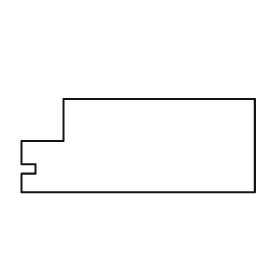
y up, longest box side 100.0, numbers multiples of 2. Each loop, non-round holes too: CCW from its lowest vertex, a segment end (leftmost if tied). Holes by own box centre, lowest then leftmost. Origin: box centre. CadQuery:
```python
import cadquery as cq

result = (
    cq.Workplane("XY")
    .moveTo(-50.0, -20.0)
    .lineTo(50.0, -20.0)
    .lineTo(50.0, 20.0)
    .lineTo(-32.0, 20.0)
    .lineTo(-32.0, 2.0)
    .lineTo(-50.0, 2.0)
    .lineTo(-50.0, -8.0)
    .lineTo(-44.0, -8.0)
    .lineTo(-44.0, -12.0)
    .lineTo(-50.0, -12.0)
    .close()
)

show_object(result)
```